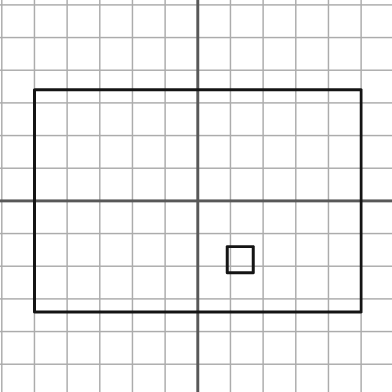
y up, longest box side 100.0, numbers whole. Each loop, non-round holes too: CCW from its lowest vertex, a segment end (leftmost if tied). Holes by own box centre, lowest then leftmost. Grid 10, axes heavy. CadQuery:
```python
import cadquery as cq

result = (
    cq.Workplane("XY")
    .moveTo(-50.0, -34.0)
    .lineTo(50.0, -34.0)
    .lineTo(50.0, 34.0)
    .lineTo(-50.0, 34.0)
    .close()
    .moveTo(9.0, -22.0)
    .lineTo(17.0, -22.0)
    .lineTo(17.0, -14.0)
    .lineTo(9.0, -14.0)
    .close()
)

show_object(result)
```